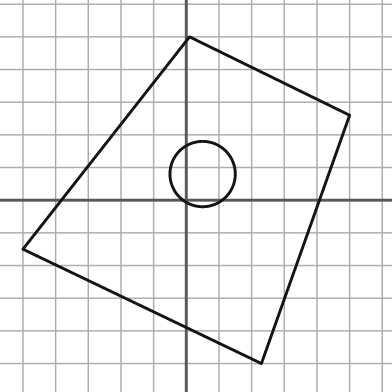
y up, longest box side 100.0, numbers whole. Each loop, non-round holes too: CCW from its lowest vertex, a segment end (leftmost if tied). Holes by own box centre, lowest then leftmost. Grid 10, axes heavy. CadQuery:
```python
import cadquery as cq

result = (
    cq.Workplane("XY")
    .moveTo(23.0, -50.0)
    .lineTo(50.0, 26.0)
    .lineTo(1.0, 50.0)
    .lineTo(-50.0, -15.0)
    .close()
    .moveTo(5.0, 8.0)
    .circle(10.0)
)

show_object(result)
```